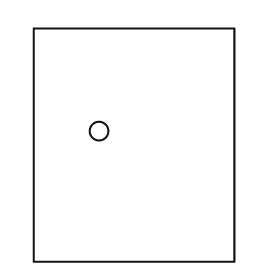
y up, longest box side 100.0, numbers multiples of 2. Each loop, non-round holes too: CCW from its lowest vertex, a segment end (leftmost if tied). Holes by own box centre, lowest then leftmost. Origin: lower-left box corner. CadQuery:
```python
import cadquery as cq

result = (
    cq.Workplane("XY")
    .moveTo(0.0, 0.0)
    .lineTo(86.0, 0.0)
    .lineTo(86.0, 100.0)
    .lineTo(0.0, 100.0)
    .close()
    .moveTo(28.0, 56.0)
    .circle(4.0)
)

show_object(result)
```